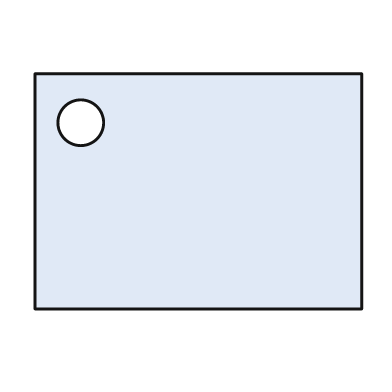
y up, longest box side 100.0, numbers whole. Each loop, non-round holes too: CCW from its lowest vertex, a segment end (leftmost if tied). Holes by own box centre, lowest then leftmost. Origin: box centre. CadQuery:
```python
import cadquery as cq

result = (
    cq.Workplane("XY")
    .moveTo(-50.0, -36.0)
    .lineTo(50.0, -36.0)
    .lineTo(50.0, 36.0)
    .lineTo(-50.0, 36.0)
    .close()
    .moveTo(-36.0, 21.0)
    .circle(7.0)
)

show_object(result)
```